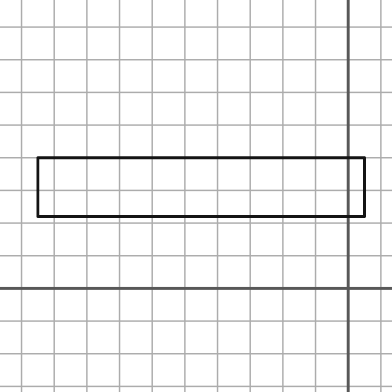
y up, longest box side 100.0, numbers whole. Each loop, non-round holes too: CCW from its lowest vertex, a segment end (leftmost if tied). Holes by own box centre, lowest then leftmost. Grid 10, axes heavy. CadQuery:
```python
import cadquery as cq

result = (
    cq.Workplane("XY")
    .moveTo(-95.0, 22.0)
    .lineTo(5.0, 22.0)
    .lineTo(5.0, 40.0)
    .lineTo(-95.0, 40.0)
    .close()
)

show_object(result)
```